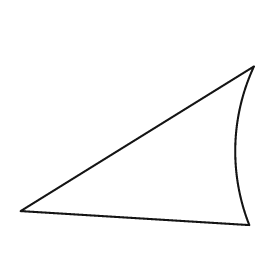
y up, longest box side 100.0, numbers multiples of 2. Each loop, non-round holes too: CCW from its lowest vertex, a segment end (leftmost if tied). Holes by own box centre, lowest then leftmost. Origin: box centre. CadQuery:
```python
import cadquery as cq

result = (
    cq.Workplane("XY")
    .moveTo(48.0, -34.0)
    .threePointArc((42.0, 0.0), (50.0, 34.0))
    .lineTo(-50.0, -28.0)
    .close()
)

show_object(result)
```